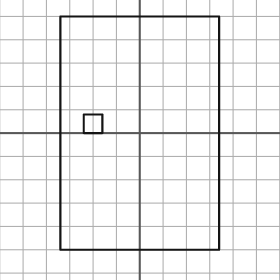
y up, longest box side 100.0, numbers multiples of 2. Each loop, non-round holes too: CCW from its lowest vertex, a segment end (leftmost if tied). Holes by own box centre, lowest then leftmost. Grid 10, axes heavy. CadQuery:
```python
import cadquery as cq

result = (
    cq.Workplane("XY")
    .moveTo(-34.0, -50.0)
    .lineTo(34.0, -50.0)
    .lineTo(34.0, 50.0)
    .lineTo(-34.0, 50.0)
    .close()
    .moveTo(-24.0, 0.0)
    .lineTo(-16.0, 0.0)
    .lineTo(-16.0, 8.0)
    .lineTo(-24.0, 8.0)
    .close()
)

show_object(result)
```